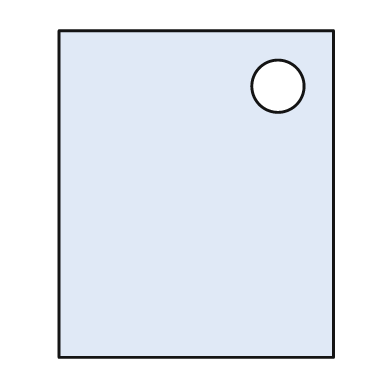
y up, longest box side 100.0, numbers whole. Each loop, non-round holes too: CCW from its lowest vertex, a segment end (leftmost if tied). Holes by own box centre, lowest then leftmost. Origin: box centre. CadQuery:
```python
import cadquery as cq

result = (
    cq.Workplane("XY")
    .moveTo(-42.0, -50.0)
    .lineTo(42.0, -50.0)
    .lineTo(42.0, 50.0)
    .lineTo(-42.0, 50.0)
    .close()
    .moveTo(25.0, 33.0)
    .circle(8.0)
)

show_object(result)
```